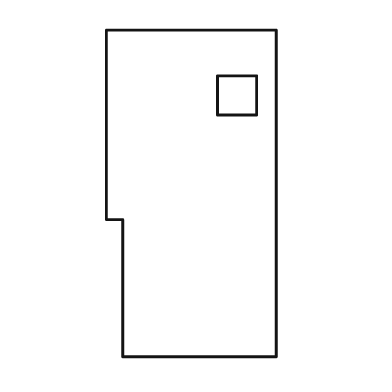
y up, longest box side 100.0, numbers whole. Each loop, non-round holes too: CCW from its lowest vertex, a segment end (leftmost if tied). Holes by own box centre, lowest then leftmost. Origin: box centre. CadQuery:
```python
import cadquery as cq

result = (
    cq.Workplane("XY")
    .moveTo(-21.0, -50.0)
    .lineTo(26.0, -50.0)
    .lineTo(26.0, 50.0)
    .lineTo(-26.0, 50.0)
    .lineTo(-26.0, -8.0)
    .lineTo(-21.0, -8.0)
    .close()
    .moveTo(8.0, 24.0)
    .lineTo(20.0, 24.0)
    .lineTo(20.0, 36.0)
    .lineTo(8.0, 36.0)
    .close()
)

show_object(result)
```